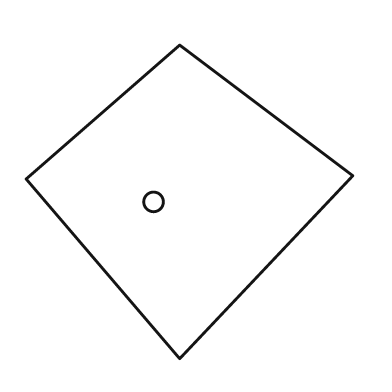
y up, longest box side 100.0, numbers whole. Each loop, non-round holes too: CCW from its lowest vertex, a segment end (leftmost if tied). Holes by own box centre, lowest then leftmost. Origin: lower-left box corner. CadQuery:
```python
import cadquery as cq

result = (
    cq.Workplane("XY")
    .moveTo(47.0, 0.0)
    .lineTo(100.0, 56.0)
    .lineTo(47.0, 96.0)
    .lineTo(0.0, 55.0)
    .close()
    .moveTo(39.0, 48.0)
    .circle(3.0)
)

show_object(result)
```